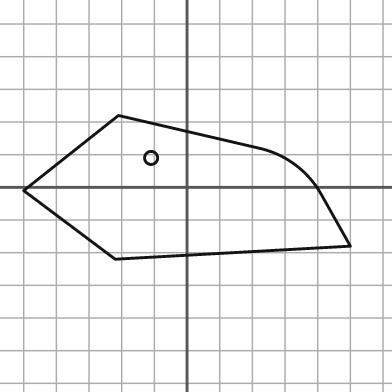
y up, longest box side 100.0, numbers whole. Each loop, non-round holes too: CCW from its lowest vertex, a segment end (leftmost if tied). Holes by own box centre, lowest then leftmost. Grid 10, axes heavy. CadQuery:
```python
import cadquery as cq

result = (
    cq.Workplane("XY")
    .moveTo(-22.0, -22.0)
    .lineTo(50.0, -18.0)
    .lineTo(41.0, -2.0)
    .threePointArc((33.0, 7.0), (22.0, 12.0))
    .lineTo(-21.0, 22.0)
    .lineTo(-50.0, -1.0)
    .close()
    .moveTo(-11.0, 9.0)
    .circle(2.0)
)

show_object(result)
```